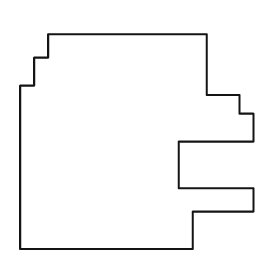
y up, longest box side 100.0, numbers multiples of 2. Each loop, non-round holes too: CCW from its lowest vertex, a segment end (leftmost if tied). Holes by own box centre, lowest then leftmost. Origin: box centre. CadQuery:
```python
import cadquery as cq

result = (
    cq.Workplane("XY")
    .moveTo(-50.0, -46.0)
    .lineTo(24.0, -46.0)
    .lineTo(24.0, -30.0)
    .lineTo(50.0, -30.0)
    .lineTo(50.0, -20.0)
    .lineTo(18.0, -20.0)
    .lineTo(18.0, 0.0)
    .lineTo(50.0, 0.0)
    .lineTo(50.0, 12.0)
    .lineTo(44.0, 12.0)
    .lineTo(44.0, 20.0)
    .lineTo(30.0, 20.0)
    .lineTo(30.0, 46.0)
    .lineTo(-38.0, 46.0)
    .lineTo(-38.0, 36.0)
    .lineTo(-44.0, 36.0)
    .lineTo(-44.0, 24.0)
    .lineTo(-50.0, 24.0)
    .close()
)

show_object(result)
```